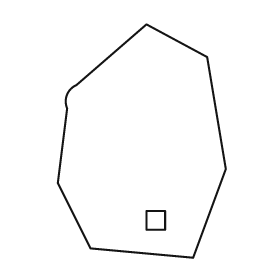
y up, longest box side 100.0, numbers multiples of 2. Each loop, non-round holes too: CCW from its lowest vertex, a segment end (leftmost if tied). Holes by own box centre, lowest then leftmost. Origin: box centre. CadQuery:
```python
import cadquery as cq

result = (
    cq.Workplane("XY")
    .moveTo(22.0, -50.0)
    .lineTo(36.0, -12.0)
    .lineTo(28.0, 36.0)
    .lineTo(2.0, 50.0)
    .lineTo(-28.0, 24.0)
    .threePointArc((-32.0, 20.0), (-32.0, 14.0))
    .lineTo(-36.0, -18.0)
    .lineTo(-22.0, -46.0)
    .close()
    .moveTo(2.0, -38.0)
    .lineTo(10.0, -38.0)
    .lineTo(10.0, -30.0)
    .lineTo(2.0, -30.0)
    .close()
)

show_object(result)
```